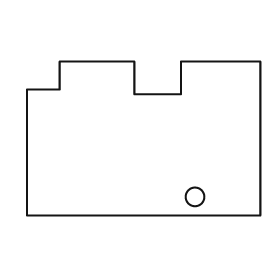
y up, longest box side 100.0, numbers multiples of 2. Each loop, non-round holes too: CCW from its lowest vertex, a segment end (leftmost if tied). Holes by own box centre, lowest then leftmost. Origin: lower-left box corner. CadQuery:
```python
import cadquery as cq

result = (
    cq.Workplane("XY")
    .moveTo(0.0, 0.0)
    .lineTo(100.0, 0.0)
    .lineTo(100.0, 66.0)
    .lineTo(66.0, 66.0)
    .lineTo(66.0, 52.0)
    .lineTo(46.0, 52.0)
    .lineTo(46.0, 66.0)
    .lineTo(14.0, 66.0)
    .lineTo(14.0, 54.0)
    .lineTo(0.0, 54.0)
    .close()
    .moveTo(72.0, 8.0)
    .circle(4.0)
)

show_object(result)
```